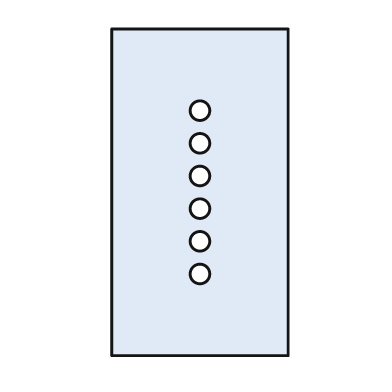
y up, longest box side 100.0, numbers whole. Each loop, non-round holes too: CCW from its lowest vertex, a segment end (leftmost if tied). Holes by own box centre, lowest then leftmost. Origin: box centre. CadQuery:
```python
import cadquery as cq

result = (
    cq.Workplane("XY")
    .moveTo(-27.0, -50.0)
    .lineTo(27.0, -50.0)
    .lineTo(27.0, 50.0)
    .lineTo(-27.0, 50.0)
    .close()
    .moveTo(0.0, -25.0)
    .circle(3.0)
    .moveTo(0.0, -15.0)
    .circle(3.0)
    .moveTo(0.0, -5.0)
    .circle(3.0)
    .moveTo(0.0, 5.0)
    .circle(3.0)
    .moveTo(0.0, 15.0)
    .circle(3.0)
    .moveTo(0.0, 25.0)
    .circle(3.0)
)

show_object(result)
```